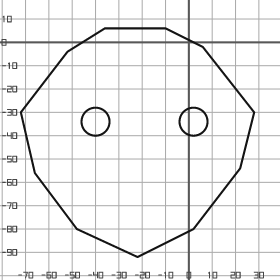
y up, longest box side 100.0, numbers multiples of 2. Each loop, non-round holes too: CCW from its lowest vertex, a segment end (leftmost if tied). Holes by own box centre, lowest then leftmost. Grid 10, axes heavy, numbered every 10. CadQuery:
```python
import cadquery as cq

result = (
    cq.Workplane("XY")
    .moveTo(-22.0, -92.0)
    .lineTo(2.0, -80.0)
    .lineTo(22.0, -54.0)
    .lineTo(28.0, -30.0)
    .lineTo(6.0, -2.0)
    .lineTo(-10.0, 6.0)
    .lineTo(-36.0, 6.0)
    .lineTo(-52.0, -4.0)
    .lineTo(-72.0, -30.0)
    .lineTo(-66.0, -56.0)
    .lineTo(-48.0, -80.0)
    .close()
    .moveTo(-40.0, -34.0)
    .circle(6.0)
    .moveTo(2.0, -34.0)
    .circle(6.0)
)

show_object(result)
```